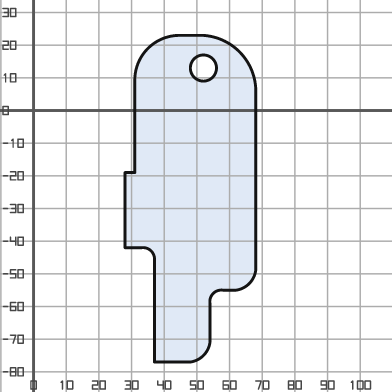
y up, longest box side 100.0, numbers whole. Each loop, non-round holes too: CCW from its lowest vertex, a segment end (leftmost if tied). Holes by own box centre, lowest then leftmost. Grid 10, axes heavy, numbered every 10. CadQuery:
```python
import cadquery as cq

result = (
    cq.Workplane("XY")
    .moveTo(37.0, -77.0)
    .lineTo(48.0, -77.0)
    .threePointArc((52.0, -75.0), (54.0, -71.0))
    .lineTo(54.0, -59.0)
    .threePointArc((55.0, -56.0), (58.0, -55.0))
    .lineTo(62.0, -55.0)
    .threePointArc((66.0, -53.0), (68.0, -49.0))
    .lineTo(68.0, 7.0)
    .threePointArc((63.0, 18.0), (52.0, 23.0))
    .lineTo(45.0, 23.0)
    .threePointArc((35.0, 19.0), (31.0, 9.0))
    .lineTo(31.0, -19.0)
    .lineTo(28.0, -19.0)
    .lineTo(28.0, -42.0)
    .lineTo(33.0, -42.0)
    .threePointArc((36.0, -43.0), (37.0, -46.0))
    .close()
    .moveTo(52.0, 13.0)
    .circle(4.0)
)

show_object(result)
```